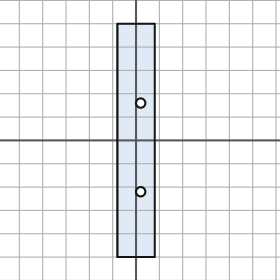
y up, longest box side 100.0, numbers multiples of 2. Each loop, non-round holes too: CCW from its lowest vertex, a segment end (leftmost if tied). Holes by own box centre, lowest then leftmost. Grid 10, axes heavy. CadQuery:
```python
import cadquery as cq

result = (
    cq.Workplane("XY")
    .moveTo(-8.0, -50.0)
    .lineTo(8.0, -50.0)
    .lineTo(8.0, 50.0)
    .lineTo(-8.0, 50.0)
    .close()
    .moveTo(2.0, -22.0)
    .circle(2.0)
    .moveTo(2.0, 16.0)
    .circle(2.0)
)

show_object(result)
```